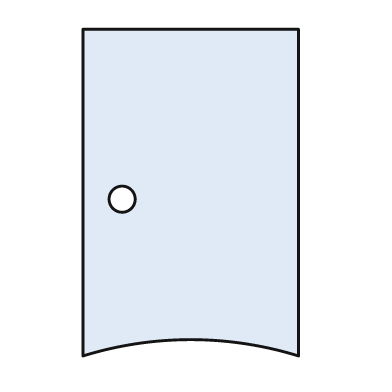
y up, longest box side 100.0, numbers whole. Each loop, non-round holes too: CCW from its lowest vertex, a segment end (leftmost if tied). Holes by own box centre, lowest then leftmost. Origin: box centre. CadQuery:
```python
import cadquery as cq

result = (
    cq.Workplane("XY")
    .moveTo(-33.0, -50.0)
    .threePointArc((0.0, -45.0), (33.0, -50.0))
    .lineTo(33.0, 50.0)
    .lineTo(-33.0, 50.0)
    .close()
    .moveTo(-21.0, -2.0)
    .circle(4.0)
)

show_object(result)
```